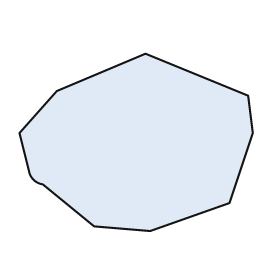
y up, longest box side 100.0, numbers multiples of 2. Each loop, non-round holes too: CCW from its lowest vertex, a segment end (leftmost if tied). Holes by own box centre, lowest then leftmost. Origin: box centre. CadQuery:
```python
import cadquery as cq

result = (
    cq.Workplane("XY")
    .moveTo(6.0, -38.0)
    .lineTo(40.0, -26.0)
    .lineTo(50.0, 4.0)
    .lineTo(48.0, 20.0)
    .lineTo(4.0, 38.0)
    .lineTo(-34.0, 22.0)
    .lineTo(-50.0, 4.0)
    .lineTo(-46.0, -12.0)
    .threePointArc((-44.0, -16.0), (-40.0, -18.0))
    .lineTo(-18.0, -36.0)
    .close()
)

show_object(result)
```